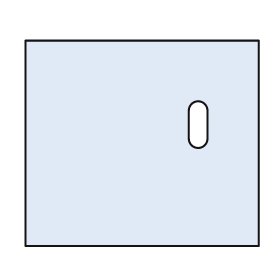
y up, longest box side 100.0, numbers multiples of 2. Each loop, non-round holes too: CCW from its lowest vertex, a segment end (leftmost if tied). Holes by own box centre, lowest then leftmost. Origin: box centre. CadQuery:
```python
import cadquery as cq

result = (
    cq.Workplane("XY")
    .moveTo(-50.0, -44.0)
    .lineTo(50.0, -44.0)
    .lineTo(50.0, 44.0)
    .lineTo(-50.0, 44.0)
    .close()
    .moveTo(20.0, 2.0)
    .threePointArc((24.0, -2.0), (28.0, 2.0))
    .lineTo(28.0, 14.0)
    .threePointArc((24.0, 18.0), (20.0, 14.0))
    .close()
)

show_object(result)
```